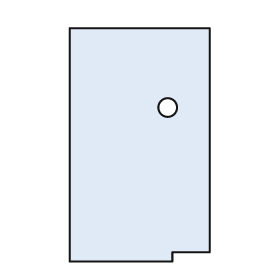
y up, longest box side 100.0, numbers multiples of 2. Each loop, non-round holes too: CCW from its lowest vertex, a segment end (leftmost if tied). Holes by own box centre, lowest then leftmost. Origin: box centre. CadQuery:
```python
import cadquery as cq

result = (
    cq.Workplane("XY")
    .moveTo(-30.0, -50.0)
    .lineTo(14.0, -50.0)
    .lineTo(14.0, -46.0)
    .lineTo(30.0, -46.0)
    .lineTo(30.0, 50.0)
    .lineTo(-30.0, 50.0)
    .close()
    .moveTo(12.0, 16.0)
    .circle(4.0)
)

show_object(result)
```